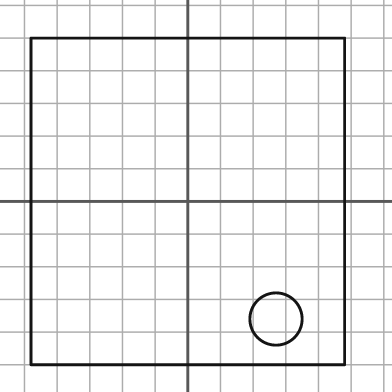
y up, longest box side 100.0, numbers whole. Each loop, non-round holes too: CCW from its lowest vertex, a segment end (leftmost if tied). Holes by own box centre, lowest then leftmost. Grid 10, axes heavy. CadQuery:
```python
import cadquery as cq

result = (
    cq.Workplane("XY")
    .moveTo(-48.0, -50.0)
    .lineTo(48.0, -50.0)
    .lineTo(48.0, 50.0)
    .lineTo(-48.0, 50.0)
    .close()
    .moveTo(27.0, -36.0)
    .circle(8.0)
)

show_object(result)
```